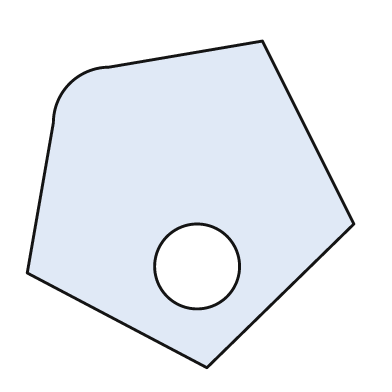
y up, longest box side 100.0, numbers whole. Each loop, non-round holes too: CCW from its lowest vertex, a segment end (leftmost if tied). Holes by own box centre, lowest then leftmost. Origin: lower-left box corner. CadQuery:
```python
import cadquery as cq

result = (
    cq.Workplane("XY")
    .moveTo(55.0, 0.0)
    .lineTo(100.0, 44.0)
    .lineTo(72.0, 100.0)
    .lineTo(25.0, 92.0)
    .threePointArc((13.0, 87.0), (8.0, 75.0))
    .lineTo(0.0, 29.0)
    .close()
    .moveTo(52.0, 31.0)
    .circle(13.0)
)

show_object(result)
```